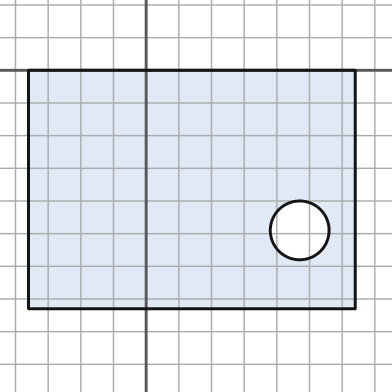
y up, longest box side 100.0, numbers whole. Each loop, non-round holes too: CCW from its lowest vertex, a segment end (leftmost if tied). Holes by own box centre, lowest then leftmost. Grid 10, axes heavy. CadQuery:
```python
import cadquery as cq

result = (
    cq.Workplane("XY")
    .moveTo(-36.0, -73.0)
    .lineTo(64.0, -73.0)
    .lineTo(64.0, 0.0)
    .lineTo(-36.0, 0.0)
    .close()
    .moveTo(47.0, -49.0)
    .circle(9.0)
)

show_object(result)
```